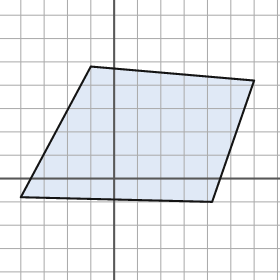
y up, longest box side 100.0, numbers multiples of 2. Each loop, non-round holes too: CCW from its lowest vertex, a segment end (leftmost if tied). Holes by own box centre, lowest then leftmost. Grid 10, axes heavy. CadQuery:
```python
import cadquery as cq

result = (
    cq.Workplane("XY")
    .moveTo(42.0, -10.0)
    .lineTo(60.0, 42.0)
    .lineTo(-10.0, 48.0)
    .lineTo(-40.0, -8.0)
    .close()
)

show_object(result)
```